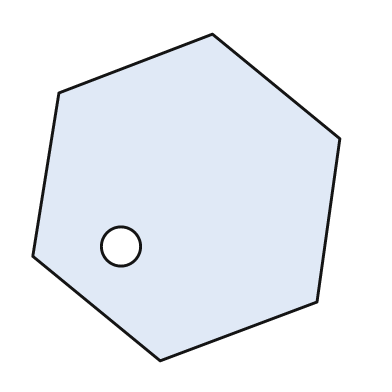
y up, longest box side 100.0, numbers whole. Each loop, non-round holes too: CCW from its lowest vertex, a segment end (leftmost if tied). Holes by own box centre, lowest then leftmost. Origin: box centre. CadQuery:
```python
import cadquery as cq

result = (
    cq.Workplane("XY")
    .moveTo(-8.0, -50.0)
    .lineTo(40.0, -32.0)
    .lineTo(47.0, 18.0)
    .lineTo(8.0, 50.0)
    .lineTo(-39.0, 32.0)
    .lineTo(-47.0, -18.0)
    .close()
    .moveTo(-20.0, -15.0)
    .circle(6.0)
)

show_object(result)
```